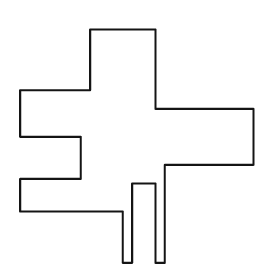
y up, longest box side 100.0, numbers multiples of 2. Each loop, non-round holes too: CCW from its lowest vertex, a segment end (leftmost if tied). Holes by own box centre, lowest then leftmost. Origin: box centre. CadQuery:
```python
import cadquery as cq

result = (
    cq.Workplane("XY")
    .moveTo(-6.0, -50.0)
    .lineTo(-2.0, -50.0)
    .lineTo(-2.0, -16.0)
    .lineTo(8.0, -16.0)
    .lineTo(8.0, -50.0)
    .lineTo(12.0, -50.0)
    .lineTo(12.0, -8.0)
    .lineTo(50.0, -8.0)
    .lineTo(50.0, 16.0)
    .lineTo(8.0, 16.0)
    .lineTo(8.0, 50.0)
    .lineTo(-20.0, 50.0)
    .lineTo(-20.0, 24.0)
    .lineTo(-50.0, 24.0)
    .lineTo(-50.0, 4.0)
    .lineTo(-24.0, 4.0)
    .lineTo(-24.0, -14.0)
    .lineTo(-50.0, -14.0)
    .lineTo(-50.0, -28.0)
    .lineTo(-6.0, -28.0)
    .close()
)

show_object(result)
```